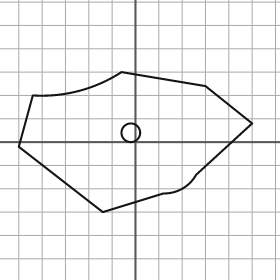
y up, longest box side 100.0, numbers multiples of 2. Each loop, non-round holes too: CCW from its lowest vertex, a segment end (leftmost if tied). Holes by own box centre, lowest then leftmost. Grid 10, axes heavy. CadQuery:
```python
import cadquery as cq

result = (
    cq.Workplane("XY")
    .moveTo(-14.0, -30.0)
    .lineTo(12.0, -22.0)
    .threePointArc((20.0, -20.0), (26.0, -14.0))
    .lineTo(50.0, 8.0)
    .lineTo(30.0, 24.0)
    .lineTo(-6.0, 30.0)
    .threePointArc((-24.0, 22.0), (-44.0, 20.0))
    .lineTo(-50.0, -2.0)
    .close()
    .moveTo(-2.0, 4.0)
    .circle(4.0)
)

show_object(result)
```